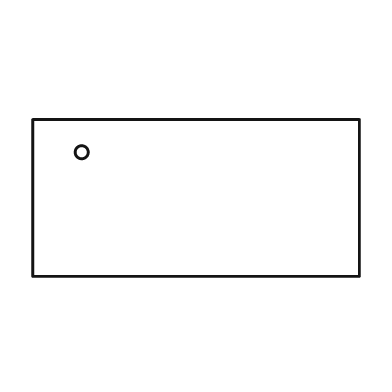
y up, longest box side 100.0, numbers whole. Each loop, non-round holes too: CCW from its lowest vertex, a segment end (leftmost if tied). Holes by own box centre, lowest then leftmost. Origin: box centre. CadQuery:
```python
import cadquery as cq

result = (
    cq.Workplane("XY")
    .moveTo(-50.0, -24.0)
    .lineTo(50.0, -24.0)
    .lineTo(50.0, 24.0)
    .lineTo(-50.0, 24.0)
    .close()
    .moveTo(-35.0, 14.0)
    .circle(2.0)
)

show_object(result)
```